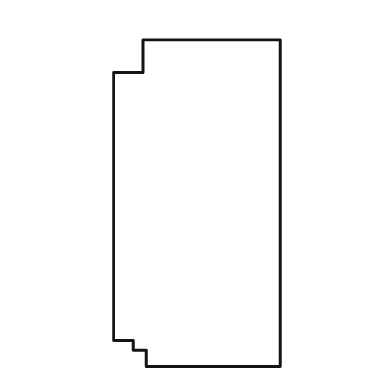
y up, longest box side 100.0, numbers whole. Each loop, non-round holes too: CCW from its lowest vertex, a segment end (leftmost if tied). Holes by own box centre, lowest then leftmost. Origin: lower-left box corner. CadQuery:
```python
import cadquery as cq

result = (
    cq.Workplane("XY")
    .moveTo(10.0, 0.0)
    .lineTo(51.0, 0.0)
    .lineTo(51.0, 100.0)
    .lineTo(9.0, 100.0)
    .lineTo(9.0, 90.0)
    .lineTo(0.0, 90.0)
    .lineTo(0.0, 8.0)
    .lineTo(6.0, 8.0)
    .lineTo(6.0, 5.0)
    .lineTo(10.0, 5.0)
    .close()
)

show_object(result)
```